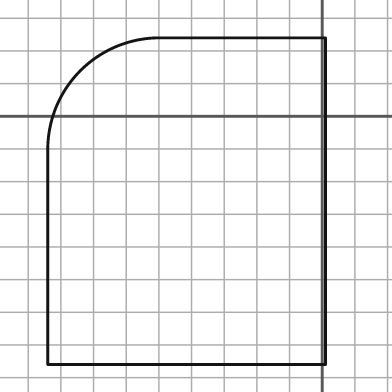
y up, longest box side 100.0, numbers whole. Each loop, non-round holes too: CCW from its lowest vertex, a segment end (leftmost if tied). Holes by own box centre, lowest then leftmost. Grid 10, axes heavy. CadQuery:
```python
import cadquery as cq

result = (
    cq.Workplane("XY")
    .moveTo(-84.0, -76.0)
    .lineTo(1.0, -76.0)
    .lineTo(1.0, 24.0)
    .lineTo(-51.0, 24.0)
    .threePointArc((-74.0, 14.0), (-84.0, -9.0))
    .close()
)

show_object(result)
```